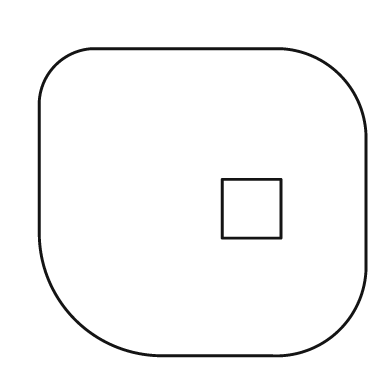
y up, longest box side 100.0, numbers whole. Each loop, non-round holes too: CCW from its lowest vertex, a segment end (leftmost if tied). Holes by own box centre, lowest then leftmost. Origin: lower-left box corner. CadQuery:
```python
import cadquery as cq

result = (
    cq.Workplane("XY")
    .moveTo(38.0, 0.0)
    .lineTo(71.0, 0.0)
    .threePointArc((92.0, 8.0), (100.0, 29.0))
    .lineTo(100.0, 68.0)
    .threePointArc((92.0, 86.0), (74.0, 94.0))
    .lineTo(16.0, 94.0)
    .threePointArc((5.0, 89.0), (0.0, 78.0))
    .lineTo(0.0, 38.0)
    .threePointArc((11.0, 11.0), (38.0, 0.0))
    .close()
    .moveTo(56.0, 36.0)
    .lineTo(74.0, 36.0)
    .lineTo(74.0, 54.0)
    .lineTo(56.0, 54.0)
    .close()
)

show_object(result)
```